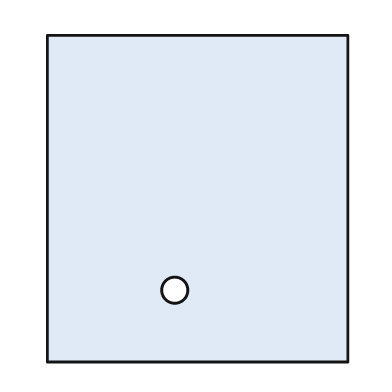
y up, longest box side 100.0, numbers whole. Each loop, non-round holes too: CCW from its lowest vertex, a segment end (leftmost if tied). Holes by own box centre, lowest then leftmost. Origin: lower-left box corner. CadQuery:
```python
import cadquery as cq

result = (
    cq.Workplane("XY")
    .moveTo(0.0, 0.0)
    .lineTo(92.0, 0.0)
    .lineTo(92.0, 100.0)
    .lineTo(0.0, 100.0)
    .close()
    .moveTo(39.0, 22.0)
    .circle(4.0)
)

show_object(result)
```